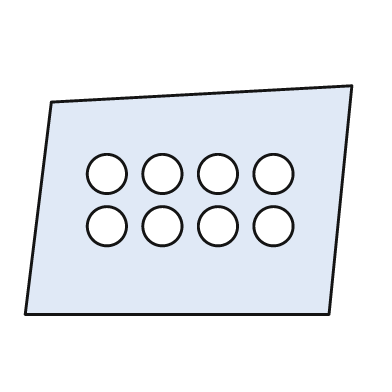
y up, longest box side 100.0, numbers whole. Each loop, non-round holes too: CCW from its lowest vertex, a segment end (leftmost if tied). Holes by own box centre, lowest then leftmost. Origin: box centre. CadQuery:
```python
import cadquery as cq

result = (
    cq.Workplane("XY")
    .moveTo(-50.0, -35.0)
    .lineTo(43.0, -35.0)
    .lineTo(50.0, 35.0)
    .lineTo(-42.0, 30.0)
    .close()
    .moveTo(-25.0, -8.0)
    .circle(6.0)
    .moveTo(-8.0, -8.0)
    .circle(6.0)
    .moveTo(9.0, -8.0)
    .circle(6.0)
    .moveTo(26.0, -8.0)
    .circle(6.0)
    .moveTo(-25.0, 8.0)
    .circle(6.0)
    .moveTo(-8.0, 8.0)
    .circle(6.0)
    .moveTo(9.0, 8.0)
    .circle(6.0)
    .moveTo(26.0, 8.0)
    .circle(6.0)
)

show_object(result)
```